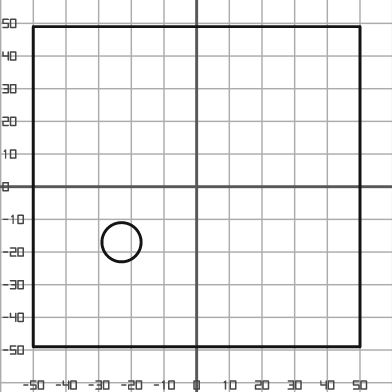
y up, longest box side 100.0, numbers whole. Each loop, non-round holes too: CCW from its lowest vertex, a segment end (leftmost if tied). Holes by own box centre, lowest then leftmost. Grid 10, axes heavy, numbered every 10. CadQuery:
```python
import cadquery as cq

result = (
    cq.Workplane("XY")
    .moveTo(-50.0, -49.0)
    .lineTo(50.0, -49.0)
    .lineTo(50.0, 49.0)
    .lineTo(-50.0, 49.0)
    .close()
    .moveTo(-23.0, -17.0)
    .circle(6.0)
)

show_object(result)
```